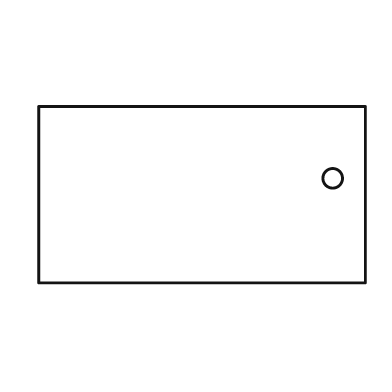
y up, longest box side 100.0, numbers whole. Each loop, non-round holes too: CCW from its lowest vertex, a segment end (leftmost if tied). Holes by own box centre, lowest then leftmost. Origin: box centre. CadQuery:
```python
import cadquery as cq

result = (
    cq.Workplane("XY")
    .moveTo(-50.0, -27.0)
    .lineTo(50.0, -27.0)
    .lineTo(50.0, 27.0)
    .lineTo(-50.0, 27.0)
    .close()
    .moveTo(40.0, 5.0)
    .circle(3.0)
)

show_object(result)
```